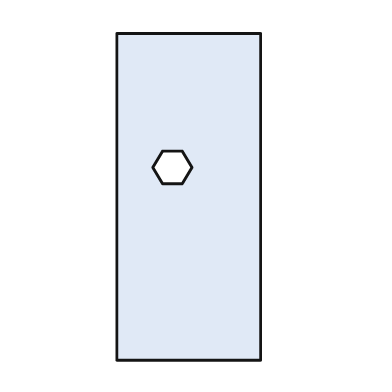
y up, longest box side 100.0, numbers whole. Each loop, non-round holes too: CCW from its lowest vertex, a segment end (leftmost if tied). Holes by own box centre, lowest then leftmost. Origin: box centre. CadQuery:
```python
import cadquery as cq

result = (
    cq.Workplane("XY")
    .moveTo(-22.0, -50.0)
    .lineTo(22.0, -50.0)
    .lineTo(22.0, 50.0)
    .lineTo(-22.0, 50.0)
    .close()
    .moveTo(-8.0, 4.0)
    .lineTo(-2.0, 4.0)
    .lineTo(1.0, 9.0)
    .lineTo(-2.0, 14.0)
    .lineTo(-8.0, 14.0)
    .lineTo(-11.0, 9.0)
    .close()
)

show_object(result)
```